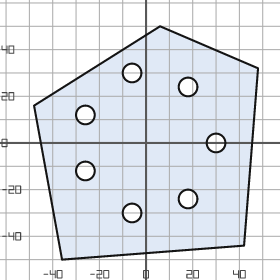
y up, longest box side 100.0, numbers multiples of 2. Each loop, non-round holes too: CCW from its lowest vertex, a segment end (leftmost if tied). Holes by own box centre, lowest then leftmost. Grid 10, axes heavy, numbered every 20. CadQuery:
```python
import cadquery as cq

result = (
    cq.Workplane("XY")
    .moveTo(-36.0, -50.0)
    .lineTo(42.0, -44.0)
    .lineTo(48.0, 32.0)
    .lineTo(6.0, 50.0)
    .lineTo(-48.0, 16.0)
    .close()
    .moveTo(-6.0, -30.0)
    .circle(4.0)
    .moveTo(18.0, -24.0)
    .circle(4.0)
    .moveTo(-26.0, -12.0)
    .circle(4.0)
    .moveTo(30.0, 0.0)
    .circle(4.0)
    .moveTo(-26.0, 12.0)
    .circle(4.0)
    .moveTo(18.0, 24.0)
    .circle(4.0)
    .moveTo(-6.0, 30.0)
    .circle(4.0)
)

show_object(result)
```